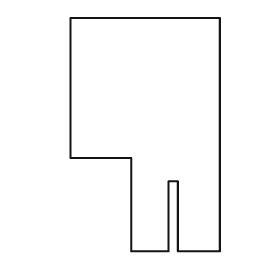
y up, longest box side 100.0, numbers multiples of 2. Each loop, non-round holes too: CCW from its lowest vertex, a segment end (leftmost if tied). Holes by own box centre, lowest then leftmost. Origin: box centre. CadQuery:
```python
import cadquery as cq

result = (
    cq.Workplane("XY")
    .moveTo(-6.0, -50.0)
    .lineTo(10.0, -50.0)
    .lineTo(10.0, -20.0)
    .lineTo(14.0, -20.0)
    .lineTo(14.0, -50.0)
    .lineTo(32.0, -50.0)
    .lineTo(32.0, 50.0)
    .lineTo(-32.0, 50.0)
    .lineTo(-32.0, -10.0)
    .lineTo(-6.0, -10.0)
    .close()
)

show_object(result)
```